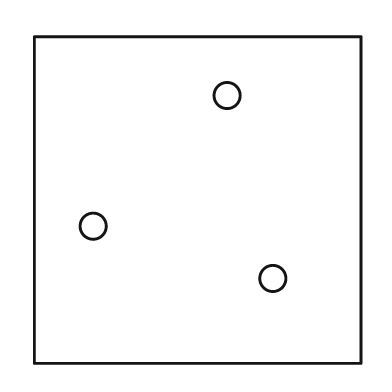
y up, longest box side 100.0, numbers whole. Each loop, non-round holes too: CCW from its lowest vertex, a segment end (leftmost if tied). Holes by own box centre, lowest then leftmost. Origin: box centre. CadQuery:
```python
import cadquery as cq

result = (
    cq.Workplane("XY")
    .moveTo(-50.0, -50.0)
    .lineTo(50.0, -50.0)
    .lineTo(50.0, 50.0)
    .lineTo(-50.0, 50.0)
    .close()
    .moveTo(23.0, -24.0)
    .circle(4.0)
    .moveTo(-32.0, -8.0)
    .circle(4.0)
    .moveTo(9.0, 32.0)
    .circle(4.0)
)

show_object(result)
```